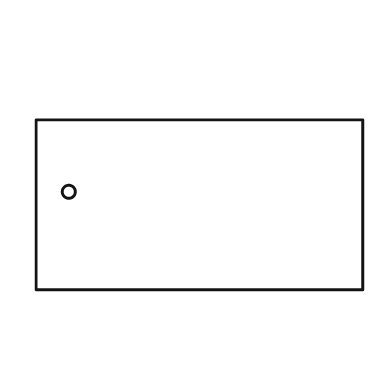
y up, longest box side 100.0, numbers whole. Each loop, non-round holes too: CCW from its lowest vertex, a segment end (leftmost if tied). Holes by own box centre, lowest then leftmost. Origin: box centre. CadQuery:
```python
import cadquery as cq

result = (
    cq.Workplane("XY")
    .moveTo(-50.0, -26.0)
    .lineTo(50.0, -26.0)
    .lineTo(50.0, 26.0)
    .lineTo(-50.0, 26.0)
    .close()
    .moveTo(-40.0, 4.0)
    .circle(2.0)
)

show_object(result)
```